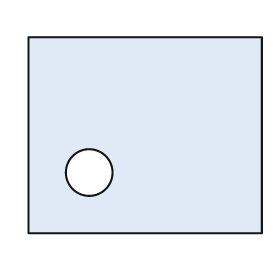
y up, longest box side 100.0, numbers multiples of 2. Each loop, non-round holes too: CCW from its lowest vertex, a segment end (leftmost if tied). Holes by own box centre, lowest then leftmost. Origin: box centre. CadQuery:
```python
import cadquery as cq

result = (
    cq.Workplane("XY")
    .moveTo(-50.0, -42.0)
    .lineTo(50.0, -42.0)
    .lineTo(50.0, 42.0)
    .lineTo(-50.0, 42.0)
    .close()
    .moveTo(-24.0, -16.0)
    .circle(10.0)
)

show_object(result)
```